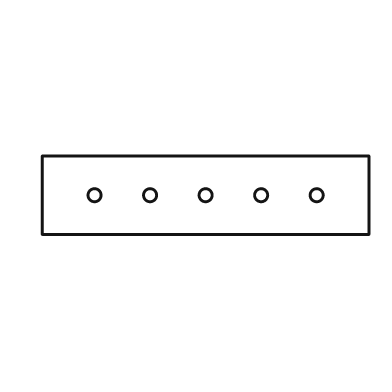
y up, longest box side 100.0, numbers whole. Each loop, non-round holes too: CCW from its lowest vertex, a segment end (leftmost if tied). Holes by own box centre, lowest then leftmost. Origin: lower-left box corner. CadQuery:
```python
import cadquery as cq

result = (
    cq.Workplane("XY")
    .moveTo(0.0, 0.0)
    .lineTo(100.0, 0.0)
    .lineTo(100.0, 24.0)
    .lineTo(0.0, 24.0)
    .close()
    .moveTo(16.0, 12.0)
    .circle(2.0)
    .moveTo(33.0, 12.0)
    .circle(2.0)
    .moveTo(50.0, 12.0)
    .circle(2.0)
    .moveTo(67.0, 12.0)
    .circle(2.0)
    .moveTo(84.0, 12.0)
    .circle(2.0)
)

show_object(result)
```